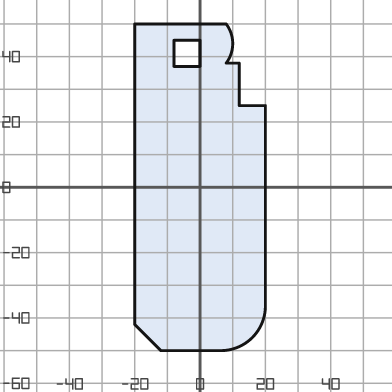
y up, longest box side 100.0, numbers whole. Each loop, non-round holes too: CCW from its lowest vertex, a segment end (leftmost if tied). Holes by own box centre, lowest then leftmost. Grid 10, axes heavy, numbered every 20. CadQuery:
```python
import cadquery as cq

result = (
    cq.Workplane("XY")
    .moveTo(-12.0, -50.0)
    .lineTo(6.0, -50.0)
    .threePointArc((16.0, -46.0), (20.0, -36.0))
    .lineTo(20.0, 25.0)
    .lineTo(12.0, 25.0)
    .lineTo(12.0, 38.0)
    .lineTo(8.0, 38.0)
    .threePointArc((10.0, 44.0), (8.0, 50.0))
    .lineTo(-20.0, 50.0)
    .lineTo(-20.0, -42.0)
    .close()
    .moveTo(-8.0, 37.0)
    .lineTo(0.0, 37.0)
    .lineTo(0.0, 45.0)
    .lineTo(-8.0, 45.0)
    .close()
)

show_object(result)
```